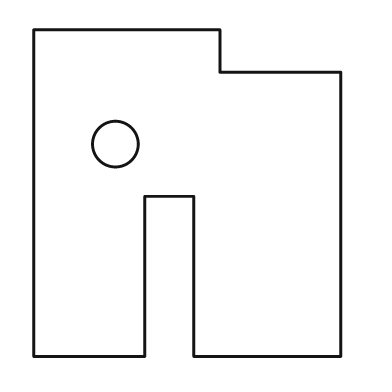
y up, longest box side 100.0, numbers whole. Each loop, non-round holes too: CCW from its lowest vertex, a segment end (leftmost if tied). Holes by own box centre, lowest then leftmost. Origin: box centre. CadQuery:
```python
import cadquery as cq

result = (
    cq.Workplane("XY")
    .moveTo(-47.0, -50.0)
    .lineTo(-13.0, -50.0)
    .lineTo(-13.0, -1.0)
    .lineTo(2.0, -1.0)
    .lineTo(2.0, -50.0)
    .lineTo(47.0, -50.0)
    .lineTo(47.0, 37.0)
    .lineTo(10.0, 37.0)
    .lineTo(10.0, 50.0)
    .lineTo(-47.0, 50.0)
    .close()
    .moveTo(-22.0, 15.0)
    .circle(7.0)
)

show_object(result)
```